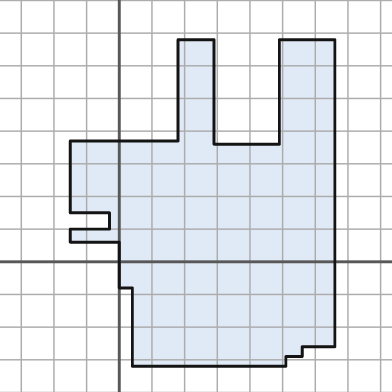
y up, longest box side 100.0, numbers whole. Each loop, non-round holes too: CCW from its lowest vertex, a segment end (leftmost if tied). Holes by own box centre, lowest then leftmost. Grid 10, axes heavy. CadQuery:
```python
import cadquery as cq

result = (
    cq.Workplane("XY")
    .moveTo(4.0, -32.0)
    .lineTo(51.0, -32.0)
    .lineTo(51.0, -29.0)
    .lineTo(56.0, -29.0)
    .lineTo(56.0, -26.0)
    .lineTo(66.0, -26.0)
    .lineTo(66.0, 68.0)
    .lineTo(49.0, 68.0)
    .lineTo(49.0, 36.0)
    .lineTo(29.0, 36.0)
    .lineTo(29.0, 68.0)
    .lineTo(18.0, 68.0)
    .lineTo(18.0, 37.0)
    .lineTo(-15.0, 37.0)
    .lineTo(-15.0, 15.0)
    .lineTo(-3.0, 15.0)
    .lineTo(-3.0, 10.0)
    .lineTo(-15.0, 10.0)
    .lineTo(-15.0, 6.0)
    .lineTo(0.0, 6.0)
    .lineTo(0.0, -8.0)
    .lineTo(4.0, -8.0)
    .close()
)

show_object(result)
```